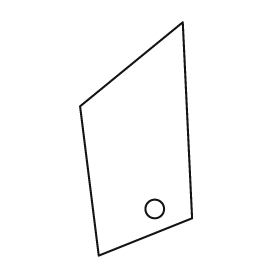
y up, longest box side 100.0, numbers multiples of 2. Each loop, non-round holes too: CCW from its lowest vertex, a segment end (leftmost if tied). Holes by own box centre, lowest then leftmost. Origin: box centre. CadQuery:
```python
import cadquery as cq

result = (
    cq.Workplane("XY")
    .moveTo(-16.0, -50.0)
    .lineTo(24.0, -34.0)
    .lineTo(20.0, 50.0)
    .lineTo(-24.0, 14.0)
    .close()
    .moveTo(8.0, -30.0)
    .circle(4.0)
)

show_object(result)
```